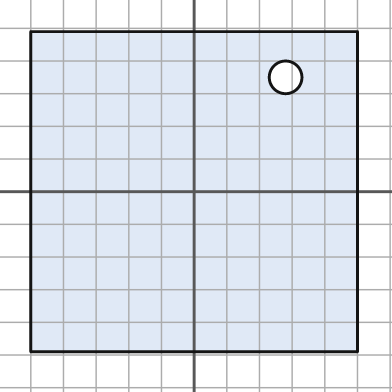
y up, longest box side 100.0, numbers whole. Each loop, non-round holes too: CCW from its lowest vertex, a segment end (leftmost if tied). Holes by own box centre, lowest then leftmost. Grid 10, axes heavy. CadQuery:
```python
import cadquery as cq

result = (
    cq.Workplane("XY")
    .moveTo(-50.0, -49.0)
    .lineTo(50.0, -49.0)
    .lineTo(50.0, 49.0)
    .lineTo(-50.0, 49.0)
    .close()
    .moveTo(28.0, 35.0)
    .circle(5.0)
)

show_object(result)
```